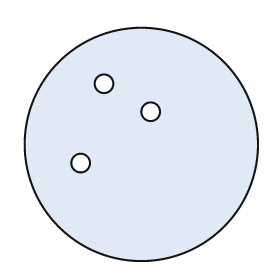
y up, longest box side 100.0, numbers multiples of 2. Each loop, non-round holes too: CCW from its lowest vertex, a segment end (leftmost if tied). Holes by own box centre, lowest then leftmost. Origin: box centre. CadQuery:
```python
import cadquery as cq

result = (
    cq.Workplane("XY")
    .moveTo(0.0, 0.0)
    .circle(50.0)
    .moveTo(-26.0, -8.0)
    .circle(4.0)
    .moveTo(4.0, 14.0)
    .circle(4.0)
    .moveTo(-16.0, 26.0)
    .circle(4.0)
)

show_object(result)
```